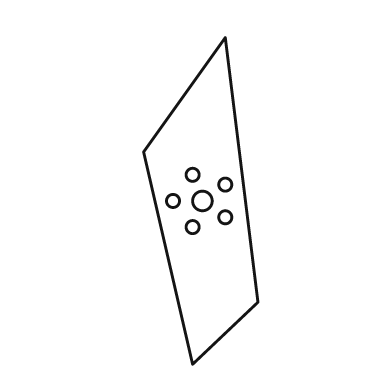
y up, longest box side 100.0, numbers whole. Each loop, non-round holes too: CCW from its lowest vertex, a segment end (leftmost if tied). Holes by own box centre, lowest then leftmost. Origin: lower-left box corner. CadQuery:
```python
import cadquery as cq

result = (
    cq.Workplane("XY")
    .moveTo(15.0, 0.0)
    .lineTo(35.0, 19.0)
    .lineTo(25.0, 100.0)
    .lineTo(0.0, 65.0)
    .close()
    .moveTo(15.0, 42.0)
    .circle(2.0)
    .moveTo(25.0, 45.0)
    .circle(2.0)
    .moveTo(9.0, 50.0)
    .circle(2.0)
    .moveTo(18.0, 50.0)
    .circle(3.0)
    .moveTo(25.0, 55.0)
    .circle(2.0)
    .moveTo(15.0, 58.0)
    .circle(2.0)
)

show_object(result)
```